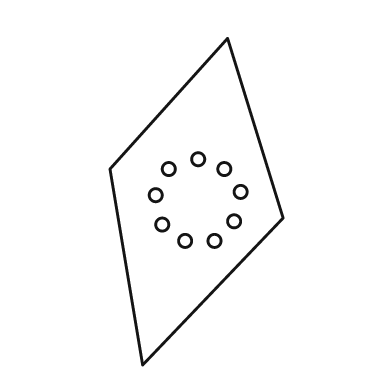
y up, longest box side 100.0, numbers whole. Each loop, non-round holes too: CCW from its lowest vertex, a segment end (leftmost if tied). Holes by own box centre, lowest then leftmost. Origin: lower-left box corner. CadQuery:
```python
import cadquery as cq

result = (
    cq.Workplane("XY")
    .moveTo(10.0, 0.0)
    .lineTo(53.0, 45.0)
    .lineTo(36.0, 100.0)
    .lineTo(0.0, 60.0)
    .close()
    .moveTo(23.0, 38.0)
    .circle(2.0)
    .moveTo(32.0, 38.0)
    .circle(2.0)
    .moveTo(16.0, 43.0)
    .circle(2.0)
    .moveTo(38.0, 44.0)
    .circle(2.0)
    .moveTo(14.0, 52.0)
    .circle(2.0)
    .moveTo(40.0, 53.0)
    .circle(2.0)
    .moveTo(18.0, 60.0)
    .circle(2.0)
    .moveTo(35.0, 60.0)
    .circle(2.0)
    .moveTo(27.0, 63.0)
    .circle(2.0)
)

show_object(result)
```